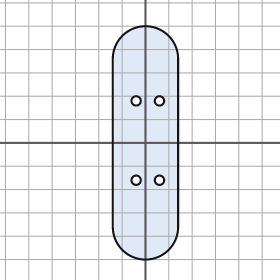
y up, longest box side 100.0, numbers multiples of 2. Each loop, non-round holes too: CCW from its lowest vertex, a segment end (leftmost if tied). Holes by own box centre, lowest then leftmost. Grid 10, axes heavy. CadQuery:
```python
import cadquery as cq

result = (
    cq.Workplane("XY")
    .moveTo(-14.0, -36.0)
    .threePointArc((0.0, -50.0), (14.0, -36.0))
    .lineTo(14.0, 36.0)
    .threePointArc((0.0, 50.0), (-14.0, 36.0))
    .close()
    .moveTo(-4.0, -16.0)
    .circle(2.0)
    .moveTo(6.0, -16.0)
    .circle(2.0)
    .moveTo(-4.0, 18.0)
    .circle(2.0)
    .moveTo(6.0, 18.0)
    .circle(2.0)
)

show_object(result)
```